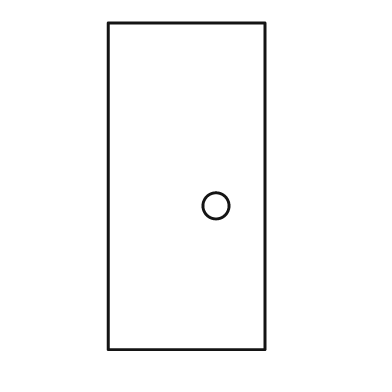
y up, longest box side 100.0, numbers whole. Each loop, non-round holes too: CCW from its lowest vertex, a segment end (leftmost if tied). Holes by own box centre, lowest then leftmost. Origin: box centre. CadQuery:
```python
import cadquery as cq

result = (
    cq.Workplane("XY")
    .moveTo(-24.0, -50.0)
    .lineTo(24.0, -50.0)
    .lineTo(24.0, 50.0)
    .lineTo(-24.0, 50.0)
    .close()
    .moveTo(9.0, -6.0)
    .circle(4.0)
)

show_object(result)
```